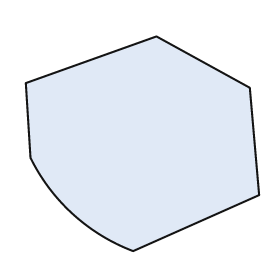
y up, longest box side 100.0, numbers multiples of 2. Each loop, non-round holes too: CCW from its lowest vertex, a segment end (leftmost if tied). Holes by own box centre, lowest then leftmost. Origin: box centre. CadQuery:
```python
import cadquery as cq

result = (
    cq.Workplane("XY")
    .moveTo(-4.0, -46.0)
    .lineTo(50.0, -22.0)
    .lineTo(46.0, 24.0)
    .lineTo(6.0, 46.0)
    .lineTo(-50.0, 26.0)
    .lineTo(-48.0, -6.0)
    .threePointArc((-30.0, -30.0), (-4.0, -46.0))
    .close()
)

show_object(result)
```